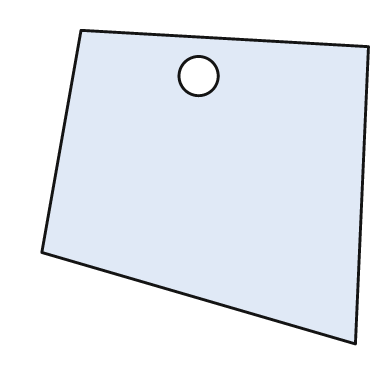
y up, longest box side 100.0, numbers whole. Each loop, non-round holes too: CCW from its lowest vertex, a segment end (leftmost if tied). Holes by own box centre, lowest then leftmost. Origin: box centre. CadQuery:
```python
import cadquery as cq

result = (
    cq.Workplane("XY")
    .moveTo(46.0, -48.0)
    .lineTo(50.0, 43.0)
    .lineTo(-38.0, 48.0)
    .lineTo(-50.0, -20.0)
    .close()
    .moveTo(-2.0, 34.0)
    .circle(6.0)
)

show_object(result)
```